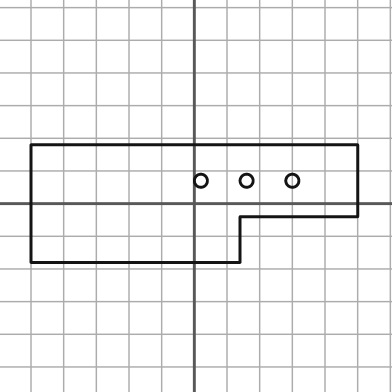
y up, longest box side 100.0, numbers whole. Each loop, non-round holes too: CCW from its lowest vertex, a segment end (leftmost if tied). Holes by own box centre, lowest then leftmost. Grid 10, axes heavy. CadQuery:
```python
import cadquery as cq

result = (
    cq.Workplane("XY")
    .moveTo(-50.0, -18.0)
    .lineTo(14.0, -18.0)
    .lineTo(14.0, -4.0)
    .lineTo(50.0, -4.0)
    .lineTo(50.0, 18.0)
    .lineTo(-50.0, 18.0)
    .close()
    .moveTo(2.0, 7.0)
    .circle(2.0)
    .moveTo(16.0, 7.0)
    .circle(2.0)
    .moveTo(30.0, 7.0)
    .circle(2.0)
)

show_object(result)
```